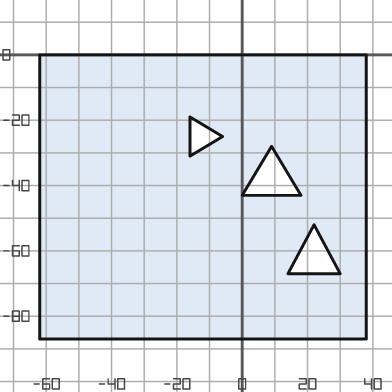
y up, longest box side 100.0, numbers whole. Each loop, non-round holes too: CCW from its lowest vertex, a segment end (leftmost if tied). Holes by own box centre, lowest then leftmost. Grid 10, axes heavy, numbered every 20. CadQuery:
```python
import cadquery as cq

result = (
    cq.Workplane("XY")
    .moveTo(-62.0, -87.0)
    .lineTo(38.0, -87.0)
    .lineTo(38.0, 0.0)
    .lineTo(-62.0, 0.0)
    .close()
    .moveTo(14.0, -67.0)
    .lineTo(30.0, -67.0)
    .lineTo(22.0, -52.0)
    .close()
    .moveTo(0.0, -43.0)
    .lineTo(18.0, -43.0)
    .lineTo(9.0, -28.0)
    .close()
    .moveTo(-16.0, -31.0)
    .lineTo(-6.0, -25.0)
    .lineTo(-16.0, -19.0)
    .close()
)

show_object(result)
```